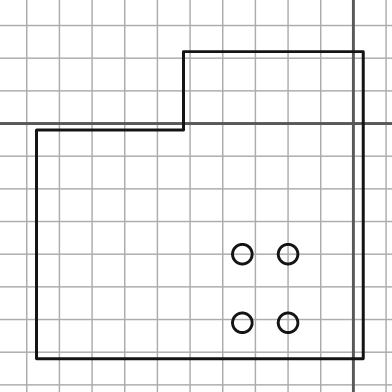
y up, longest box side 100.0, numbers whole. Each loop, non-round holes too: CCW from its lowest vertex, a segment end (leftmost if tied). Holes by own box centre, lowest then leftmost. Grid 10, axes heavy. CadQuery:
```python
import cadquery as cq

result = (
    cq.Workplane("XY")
    .moveTo(-97.0, -72.0)
    .lineTo(3.0, -72.0)
    .lineTo(3.0, 22.0)
    .lineTo(-52.0, 22.0)
    .lineTo(-52.0, -2.0)
    .lineTo(-97.0, -2.0)
    .close()
    .moveTo(-34.0, -61.0)
    .circle(3.0)
    .moveTo(-20.0, -61.0)
    .circle(3.0)
    .moveTo(-34.0, -40.0)
    .circle(3.0)
    .moveTo(-20.0, -40.0)
    .circle(3.0)
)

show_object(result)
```